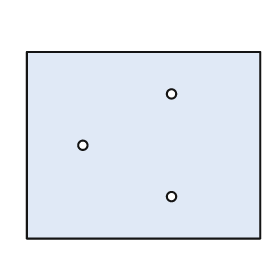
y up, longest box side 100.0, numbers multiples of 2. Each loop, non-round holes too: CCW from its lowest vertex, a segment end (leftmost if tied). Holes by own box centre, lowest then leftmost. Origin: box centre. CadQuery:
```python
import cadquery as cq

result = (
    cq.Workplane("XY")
    .moveTo(-50.0, -40.0)
    .lineTo(50.0, -40.0)
    .lineTo(50.0, 40.0)
    .lineTo(-50.0, 40.0)
    .close()
    .moveTo(12.0, -22.0)
    .circle(2.0)
    .moveTo(-26.0, 0.0)
    .circle(2.0)
    .moveTo(12.0, 22.0)
    .circle(2.0)
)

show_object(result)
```